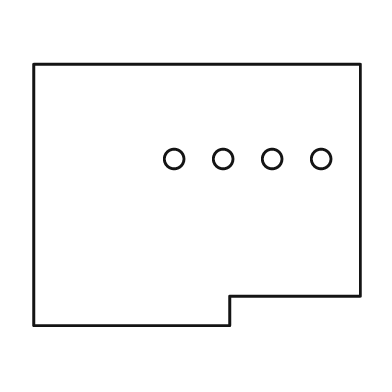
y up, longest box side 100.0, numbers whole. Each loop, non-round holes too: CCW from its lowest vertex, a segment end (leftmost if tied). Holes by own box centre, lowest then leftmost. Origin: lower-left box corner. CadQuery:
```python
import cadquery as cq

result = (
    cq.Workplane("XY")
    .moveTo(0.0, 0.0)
    .lineTo(60.0, 0.0)
    .lineTo(60.0, 9.0)
    .lineTo(100.0, 9.0)
    .lineTo(100.0, 80.0)
    .lineTo(0.0, 80.0)
    .close()
    .moveTo(43.0, 51.0)
    .circle(3.0)
    .moveTo(58.0, 51.0)
    .circle(3.0)
    .moveTo(73.0, 51.0)
    .circle(3.0)
    .moveTo(88.0, 51.0)
    .circle(3.0)
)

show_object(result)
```